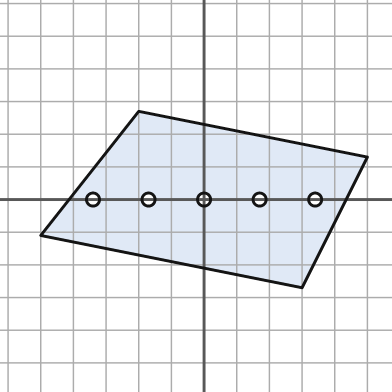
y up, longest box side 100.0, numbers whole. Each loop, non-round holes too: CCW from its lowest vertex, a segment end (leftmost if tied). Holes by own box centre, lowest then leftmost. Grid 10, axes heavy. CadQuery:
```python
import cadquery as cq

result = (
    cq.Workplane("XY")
    .moveTo(30.0, -27.0)
    .lineTo(50.0, 13.0)
    .lineTo(-20.0, 27.0)
    .lineTo(-50.0, -11.0)
    .close()
    .moveTo(-34.0, 0.0)
    .circle(2.0)
    .moveTo(-17.0, 0.0)
    .circle(2.0)
    .moveTo(0.0, 0.0)
    .circle(2.0)
    .moveTo(17.0, 0.0)
    .circle(2.0)
    .moveTo(34.0, 0.0)
    .circle(2.0)
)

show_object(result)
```